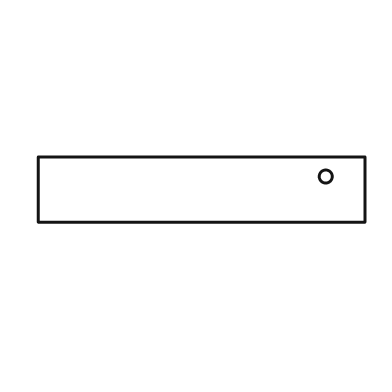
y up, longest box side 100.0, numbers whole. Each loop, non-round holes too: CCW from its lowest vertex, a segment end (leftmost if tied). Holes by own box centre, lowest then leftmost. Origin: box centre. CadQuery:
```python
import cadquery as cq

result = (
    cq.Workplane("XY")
    .moveTo(-50.0, -10.0)
    .lineTo(50.0, -10.0)
    .lineTo(50.0, 10.0)
    .lineTo(-50.0, 10.0)
    .close()
    .moveTo(38.0, 4.0)
    .circle(2.0)
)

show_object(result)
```